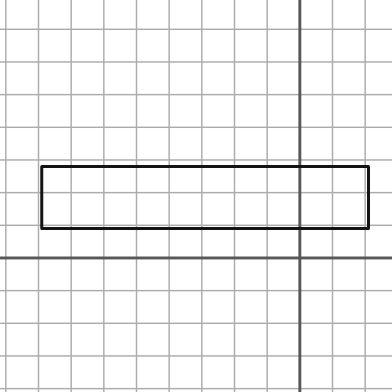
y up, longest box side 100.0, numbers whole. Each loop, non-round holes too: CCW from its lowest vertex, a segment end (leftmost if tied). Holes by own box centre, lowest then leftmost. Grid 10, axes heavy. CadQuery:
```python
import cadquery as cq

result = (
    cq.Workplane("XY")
    .moveTo(-79.0, 9.0)
    .lineTo(21.0, 9.0)
    .lineTo(21.0, 28.0)
    .lineTo(-79.0, 28.0)
    .close()
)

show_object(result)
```